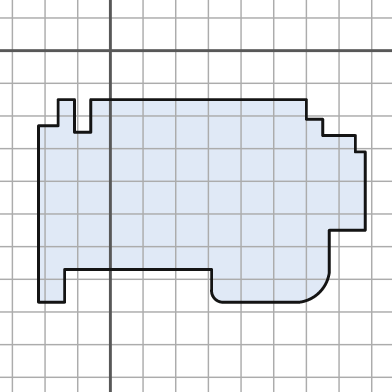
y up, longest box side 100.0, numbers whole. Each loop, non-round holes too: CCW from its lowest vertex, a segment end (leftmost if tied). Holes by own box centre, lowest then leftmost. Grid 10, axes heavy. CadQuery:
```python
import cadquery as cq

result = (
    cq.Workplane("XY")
    .moveTo(-22.0, -77.0)
    .lineTo(-14.0, -77.0)
    .lineTo(-14.0, -67.0)
    .lineTo(31.0, -67.0)
    .lineTo(31.0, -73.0)
    .threePointArc((32.0, -76.0), (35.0, -77.0))
    .lineTo(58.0, -77.0)
    .threePointArc((64.0, -74.0), (67.0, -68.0))
    .lineTo(67.0, -55.0)
    .lineTo(78.0, -55.0)
    .lineTo(78.0, -31.0)
    .lineTo(75.0, -31.0)
    .lineTo(75.0, -26.0)
    .lineTo(65.0, -26.0)
    .lineTo(65.0, -21.0)
    .lineTo(60.0, -21.0)
    .lineTo(60.0, -15.0)
    .lineTo(-6.0, -15.0)
    .lineTo(-6.0, -25.0)
    .lineTo(-11.0, -25.0)
    .lineTo(-11.0, -15.0)
    .lineTo(-16.0, -15.0)
    .lineTo(-16.0, -23.0)
    .lineTo(-22.0, -23.0)
    .close()
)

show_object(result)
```